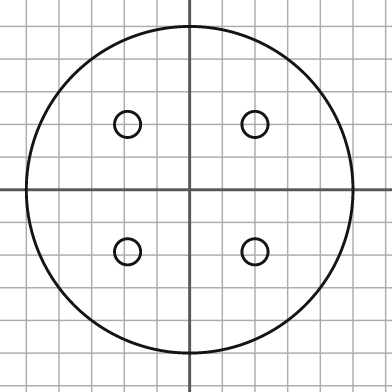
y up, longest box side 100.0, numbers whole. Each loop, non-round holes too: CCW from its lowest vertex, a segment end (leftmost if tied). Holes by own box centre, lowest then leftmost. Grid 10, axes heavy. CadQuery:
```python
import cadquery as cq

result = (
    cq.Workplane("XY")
    .moveTo(0.0, 0.0)
    .circle(50.0)
    .moveTo(-19.0, -19.0)
    .circle(4.0)
    .moveTo(20.0, -19.0)
    .circle(4.0)
    .moveTo(-19.0, 20.0)
    .circle(4.0)
    .moveTo(20.0, 20.0)
    .circle(4.0)
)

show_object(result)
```